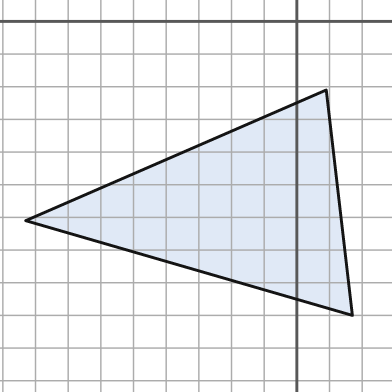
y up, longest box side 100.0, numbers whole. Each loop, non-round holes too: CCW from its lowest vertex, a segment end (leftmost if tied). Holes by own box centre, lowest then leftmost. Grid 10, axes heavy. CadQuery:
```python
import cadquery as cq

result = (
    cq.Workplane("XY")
    .moveTo(17.0, -90.0)
    .lineTo(9.0, -21.0)
    .lineTo(-83.0, -61.0)
    .close()
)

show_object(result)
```